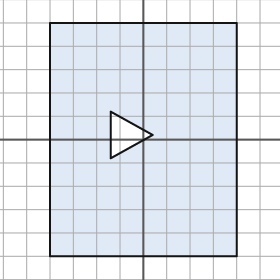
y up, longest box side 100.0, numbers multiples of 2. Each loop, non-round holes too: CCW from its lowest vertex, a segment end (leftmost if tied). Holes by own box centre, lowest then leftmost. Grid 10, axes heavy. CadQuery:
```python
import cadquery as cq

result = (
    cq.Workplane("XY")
    .moveTo(-40.0, -50.0)
    .lineTo(40.0, -50.0)
    .lineTo(40.0, 50.0)
    .lineTo(-40.0, 50.0)
    .close()
    .moveTo(-14.0, -8.0)
    .lineTo(4.0, 2.0)
    .lineTo(-14.0, 12.0)
    .close()
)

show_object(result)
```